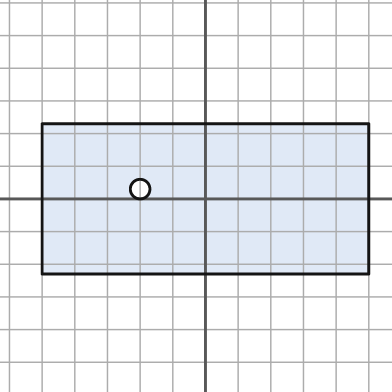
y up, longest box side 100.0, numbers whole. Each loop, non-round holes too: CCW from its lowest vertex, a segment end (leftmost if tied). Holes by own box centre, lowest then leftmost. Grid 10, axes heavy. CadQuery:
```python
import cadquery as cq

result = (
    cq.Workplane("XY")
    .moveTo(-50.0, -23.0)
    .lineTo(50.0, -23.0)
    .lineTo(50.0, 23.0)
    .lineTo(-50.0, 23.0)
    .close()
    .moveTo(-20.0, 3.0)
    .circle(3.0)
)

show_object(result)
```